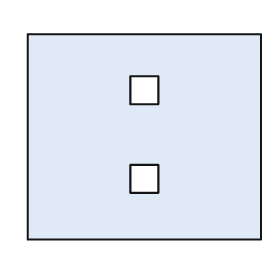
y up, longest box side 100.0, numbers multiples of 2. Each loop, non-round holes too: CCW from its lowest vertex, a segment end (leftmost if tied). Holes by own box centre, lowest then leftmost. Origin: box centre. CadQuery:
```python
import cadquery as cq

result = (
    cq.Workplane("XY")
    .moveTo(-50.0, -44.0)
    .lineTo(50.0, -44.0)
    .lineTo(50.0, 44.0)
    .lineTo(-50.0, 44.0)
    .close()
    .moveTo(-6.0, -24.0)
    .lineTo(6.0, -24.0)
    .lineTo(6.0, -12.0)
    .lineTo(-6.0, -12.0)
    .close()
    .moveTo(-6.0, 14.0)
    .lineTo(6.0, 14.0)
    .lineTo(6.0, 26.0)
    .lineTo(-6.0, 26.0)
    .close()
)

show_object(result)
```